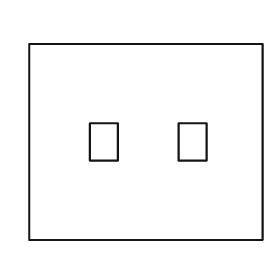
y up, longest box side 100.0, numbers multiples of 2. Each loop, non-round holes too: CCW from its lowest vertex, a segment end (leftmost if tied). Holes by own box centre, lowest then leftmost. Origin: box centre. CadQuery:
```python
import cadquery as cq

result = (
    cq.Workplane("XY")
    .moveTo(-50.0, -42.0)
    .lineTo(50.0, -42.0)
    .lineTo(50.0, 42.0)
    .lineTo(-50.0, 42.0)
    .close()
    .moveTo(-24.0, -8.0)
    .lineTo(-12.0, -8.0)
    .lineTo(-12.0, 8.0)
    .lineTo(-24.0, 8.0)
    .close()
    .moveTo(14.0, -8.0)
    .lineTo(26.0, -8.0)
    .lineTo(26.0, 8.0)
    .lineTo(14.0, 8.0)
    .close()
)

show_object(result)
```